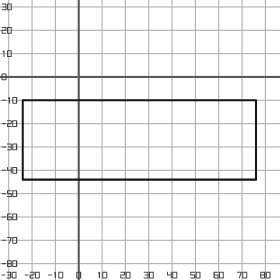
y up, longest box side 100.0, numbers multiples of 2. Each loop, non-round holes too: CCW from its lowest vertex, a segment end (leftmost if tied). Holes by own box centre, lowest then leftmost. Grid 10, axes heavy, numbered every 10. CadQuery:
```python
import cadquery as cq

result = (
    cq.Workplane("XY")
    .moveTo(-24.0, -44.0)
    .lineTo(76.0, -44.0)
    .lineTo(76.0, -10.0)
    .lineTo(-24.0, -10.0)
    .close()
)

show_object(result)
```